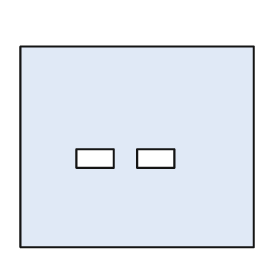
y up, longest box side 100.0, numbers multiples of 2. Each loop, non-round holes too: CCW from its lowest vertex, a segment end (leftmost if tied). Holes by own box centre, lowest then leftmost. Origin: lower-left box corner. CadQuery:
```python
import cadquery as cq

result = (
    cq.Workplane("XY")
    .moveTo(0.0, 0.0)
    .lineTo(100.0, 0.0)
    .lineTo(100.0, 86.0)
    .lineTo(0.0, 86.0)
    .close()
    .moveTo(24.0, 34.0)
    .lineTo(40.0, 34.0)
    .lineTo(40.0, 42.0)
    .lineTo(24.0, 42.0)
    .close()
    .moveTo(50.0, 34.0)
    .lineTo(66.0, 34.0)
    .lineTo(66.0, 42.0)
    .lineTo(50.0, 42.0)
    .close()
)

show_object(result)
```